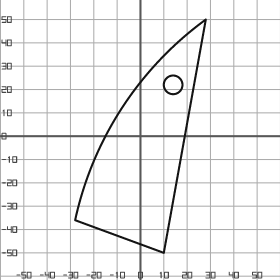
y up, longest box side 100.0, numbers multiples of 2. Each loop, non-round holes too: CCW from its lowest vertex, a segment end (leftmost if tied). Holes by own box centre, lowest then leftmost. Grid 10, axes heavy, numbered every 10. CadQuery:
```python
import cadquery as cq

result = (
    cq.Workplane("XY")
    .moveTo(10.0, -50.0)
    .lineTo(28.0, 50.0)
    .threePointArc((-8.0, 12.0), (-28.0, -36.0))
    .close()
    .moveTo(14.0, 22.0)
    .circle(4.0)
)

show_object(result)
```